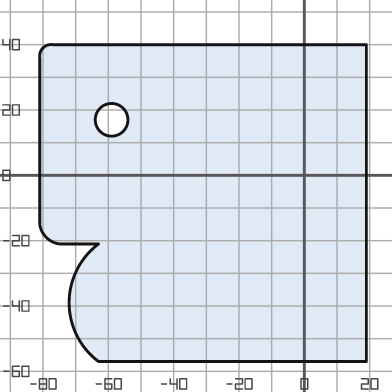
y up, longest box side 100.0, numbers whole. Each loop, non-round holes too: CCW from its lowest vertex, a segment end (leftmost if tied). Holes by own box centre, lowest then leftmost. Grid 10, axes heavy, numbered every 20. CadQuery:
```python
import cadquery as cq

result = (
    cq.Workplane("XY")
    .moveTo(-63.0, -57.0)
    .lineTo(19.0, -57.0)
    .lineTo(19.0, 40.0)
    .lineTo(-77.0, 40.0)
    .threePointArc((-80.0, 39.0), (-81.0, 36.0))
    .lineTo(-81.0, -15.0)
    .threePointArc((-79.0, -19.0), (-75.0, -21.0))
    .lineTo(-63.0, -21.0)
    .threePointArc((-72.0, -39.0), (-63.0, -57.0))
    .close()
    .moveTo(-59.0, 17.0)
    .circle(5.0)
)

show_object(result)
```